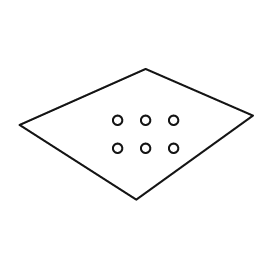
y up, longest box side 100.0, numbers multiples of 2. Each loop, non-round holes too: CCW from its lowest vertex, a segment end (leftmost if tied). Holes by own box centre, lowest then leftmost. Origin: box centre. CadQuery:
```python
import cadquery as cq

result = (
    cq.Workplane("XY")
    .moveTo(0.0, -28.0)
    .lineTo(50.0, 8.0)
    .lineTo(4.0, 28.0)
    .lineTo(-50.0, 4.0)
    .close()
    .moveTo(-8.0, -6.0)
    .circle(2.0)
    .moveTo(4.0, -6.0)
    .circle(2.0)
    .moveTo(16.0, -6.0)
    .circle(2.0)
    .moveTo(-8.0, 6.0)
    .circle(2.0)
    .moveTo(4.0, 6.0)
    .circle(2.0)
    .moveTo(16.0, 6.0)
    .circle(2.0)
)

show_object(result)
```